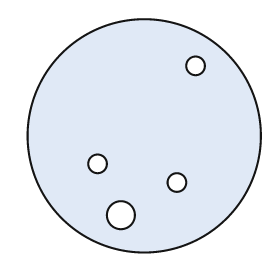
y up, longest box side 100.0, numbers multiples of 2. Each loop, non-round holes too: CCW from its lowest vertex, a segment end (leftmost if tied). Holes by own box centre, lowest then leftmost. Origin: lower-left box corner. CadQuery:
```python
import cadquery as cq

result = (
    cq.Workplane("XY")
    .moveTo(50.0, 50.0)
    .circle(50.0)
    .moveTo(40.0, 16.0)
    .circle(6.0)
    .moveTo(64.0, 30.0)
    .circle(4.0)
    .moveTo(30.0, 38.0)
    .circle(4.0)
    .moveTo(72.0, 80.0)
    .circle(4.0)
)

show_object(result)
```